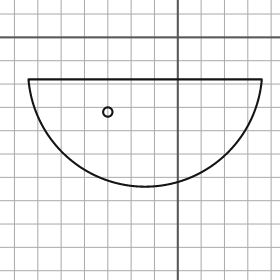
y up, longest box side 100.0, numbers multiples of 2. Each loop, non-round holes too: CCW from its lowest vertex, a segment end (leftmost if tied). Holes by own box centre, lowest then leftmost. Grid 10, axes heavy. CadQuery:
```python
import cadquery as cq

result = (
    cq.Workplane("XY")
    .moveTo(-64.0, -18.0)
    .threePointArc((-14.0, -64.0), (36.0, -18.0))
    .close()
    .moveTo(-30.0, -32.0)
    .circle(2.0)
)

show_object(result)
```